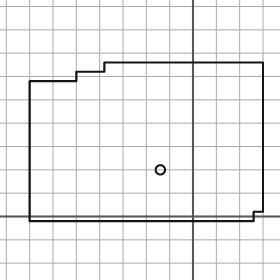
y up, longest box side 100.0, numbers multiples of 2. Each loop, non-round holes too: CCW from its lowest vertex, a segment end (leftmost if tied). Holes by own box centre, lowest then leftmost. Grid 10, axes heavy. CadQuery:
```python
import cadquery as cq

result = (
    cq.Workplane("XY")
    .moveTo(-70.0, -2.0)
    .lineTo(26.0, -2.0)
    .lineTo(26.0, 2.0)
    .lineTo(30.0, 2.0)
    .lineTo(30.0, 66.0)
    .lineTo(-38.0, 66.0)
    .lineTo(-38.0, 62.0)
    .lineTo(-50.0, 62.0)
    .lineTo(-50.0, 58.0)
    .lineTo(-70.0, 58.0)
    .close()
    .moveTo(-14.0, 20.0)
    .circle(2.0)
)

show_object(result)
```